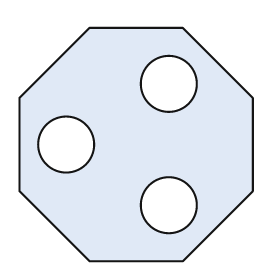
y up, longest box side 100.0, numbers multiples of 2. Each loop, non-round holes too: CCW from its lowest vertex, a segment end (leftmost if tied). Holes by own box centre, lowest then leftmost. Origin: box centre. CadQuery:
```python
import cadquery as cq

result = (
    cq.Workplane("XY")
    .moveTo(-20.0, -50.0)
    .lineTo(20.0, -50.0)
    .lineTo(50.0, -20.0)
    .lineTo(50.0, 20.0)
    .lineTo(20.0, 50.0)
    .lineTo(-20.0, 50.0)
    .lineTo(-50.0, 20.0)
    .lineTo(-50.0, -20.0)
    .close()
    .moveTo(14.0, -26.0)
    .circle(12.0)
    .moveTo(-30.0, 0.0)
    .circle(12.0)
    .moveTo(14.0, 26.0)
    .circle(12.0)
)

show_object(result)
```